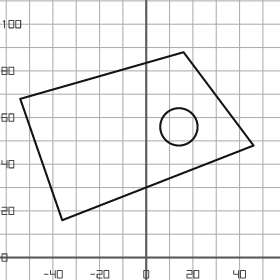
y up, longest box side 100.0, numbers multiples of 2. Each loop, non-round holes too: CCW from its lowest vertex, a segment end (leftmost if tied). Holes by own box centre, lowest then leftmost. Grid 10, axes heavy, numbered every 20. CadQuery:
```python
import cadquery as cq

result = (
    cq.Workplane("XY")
    .moveTo(-36.0, 16.0)
    .lineTo(46.0, 48.0)
    .lineTo(16.0, 88.0)
    .lineTo(-54.0, 68.0)
    .close()
    .moveTo(14.0, 56.0)
    .circle(8.0)
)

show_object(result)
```